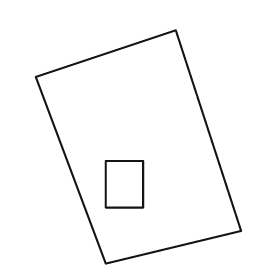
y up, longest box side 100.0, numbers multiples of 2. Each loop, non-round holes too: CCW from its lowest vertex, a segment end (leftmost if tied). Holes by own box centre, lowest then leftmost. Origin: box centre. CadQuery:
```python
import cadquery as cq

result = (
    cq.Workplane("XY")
    .moveTo(-14.0, -50.0)
    .lineTo(44.0, -36.0)
    .lineTo(16.0, 50.0)
    .lineTo(-44.0, 30.0)
    .close()
    .moveTo(-14.0, -26.0)
    .lineTo(2.0, -26.0)
    .lineTo(2.0, -6.0)
    .lineTo(-14.0, -6.0)
    .close()
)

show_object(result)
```